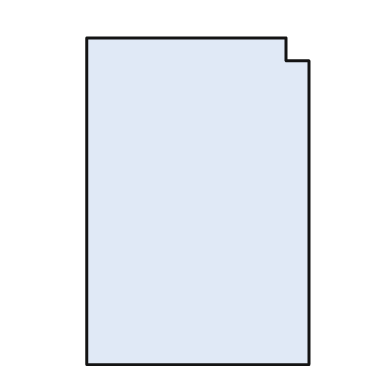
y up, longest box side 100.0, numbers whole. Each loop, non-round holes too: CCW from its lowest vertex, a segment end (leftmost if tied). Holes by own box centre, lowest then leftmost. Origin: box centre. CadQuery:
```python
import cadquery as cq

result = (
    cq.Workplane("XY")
    .moveTo(-34.0, -50.0)
    .lineTo(34.0, -50.0)
    .lineTo(34.0, 43.0)
    .lineTo(27.0, 43.0)
    .lineTo(27.0, 50.0)
    .lineTo(-34.0, 50.0)
    .close()
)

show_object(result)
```